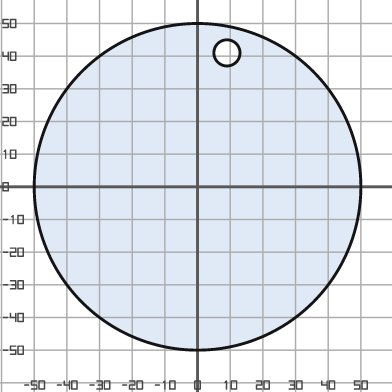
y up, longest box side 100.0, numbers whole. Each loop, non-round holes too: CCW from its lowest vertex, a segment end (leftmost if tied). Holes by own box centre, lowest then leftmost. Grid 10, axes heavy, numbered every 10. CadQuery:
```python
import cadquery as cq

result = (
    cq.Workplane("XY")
    .moveTo(0.0, 0.0)
    .circle(50.0)
    .moveTo(9.0, 41.0)
    .circle(4.0)
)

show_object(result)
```